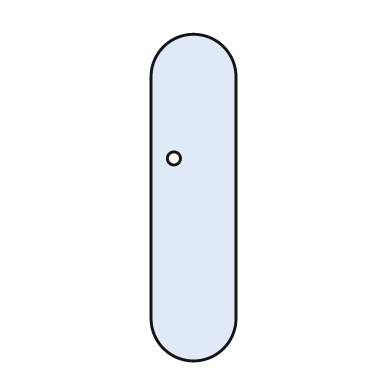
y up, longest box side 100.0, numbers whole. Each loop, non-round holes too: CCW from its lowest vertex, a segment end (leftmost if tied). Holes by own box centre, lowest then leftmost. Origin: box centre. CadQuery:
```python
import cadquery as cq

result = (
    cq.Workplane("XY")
    .moveTo(-13.0, -37.0)
    .threePointArc((0.0, -50.0), (13.0, -37.0))
    .lineTo(13.0, 37.0)
    .threePointArc((0.0, 50.0), (-13.0, 37.0))
    .close()
    .moveTo(-6.0, 12.0)
    .circle(2.0)
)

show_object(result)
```